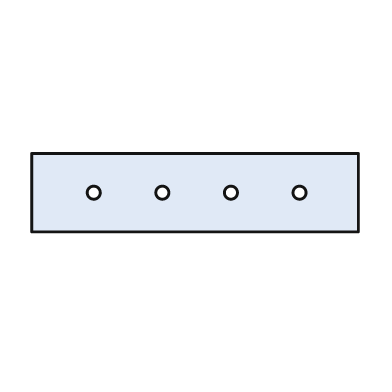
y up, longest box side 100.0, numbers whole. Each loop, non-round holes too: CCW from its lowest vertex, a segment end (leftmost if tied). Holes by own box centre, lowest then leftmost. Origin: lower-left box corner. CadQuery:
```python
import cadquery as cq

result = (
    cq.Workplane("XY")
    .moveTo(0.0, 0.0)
    .lineTo(100.0, 0.0)
    .lineTo(100.0, 24.0)
    .lineTo(0.0, 24.0)
    .close()
    .moveTo(19.0, 12.0)
    .circle(2.0)
    .moveTo(40.0, 12.0)
    .circle(2.0)
    .moveTo(61.0, 12.0)
    .circle(2.0)
    .moveTo(82.0, 12.0)
    .circle(2.0)
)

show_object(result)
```